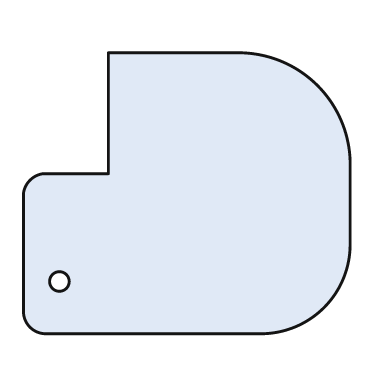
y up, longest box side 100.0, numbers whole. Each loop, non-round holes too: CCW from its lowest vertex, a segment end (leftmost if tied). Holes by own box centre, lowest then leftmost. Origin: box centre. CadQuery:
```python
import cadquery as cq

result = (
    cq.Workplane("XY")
    .moveTo(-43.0, -43.0)
    .lineTo(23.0, -43.0)
    .threePointArc((42.0, -35.0), (50.0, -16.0))
    .lineTo(50.0, 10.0)
    .threePointArc((40.0, 33.0), (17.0, 43.0))
    .lineTo(-24.0, 43.0)
    .lineTo(-24.0, 6.0)
    .lineTo(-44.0, 6.0)
    .threePointArc((-48.0, 4.0), (-50.0, 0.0))
    .lineTo(-50.0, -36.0)
    .threePointArc((-48.0, -41.0), (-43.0, -43.0))
    .close()
    .moveTo(-39.0, -27.0)
    .circle(3.0)
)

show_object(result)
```